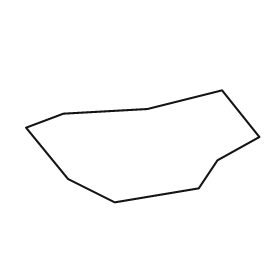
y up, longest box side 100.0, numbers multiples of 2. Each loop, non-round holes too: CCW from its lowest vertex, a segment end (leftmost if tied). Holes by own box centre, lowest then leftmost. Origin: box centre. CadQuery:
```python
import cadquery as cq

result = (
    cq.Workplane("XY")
    .moveTo(-12.0, -24.0)
    .lineTo(24.0, -18.0)
    .lineTo(32.0, -6.0)
    .lineTo(50.0, 4.0)
    .lineTo(34.0, 24.0)
    .lineTo(2.0, 16.0)
    .lineTo(-34.0, 14.0)
    .lineTo(-50.0, 8.0)
    .lineTo(-32.0, -14.0)
    .close()
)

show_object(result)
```